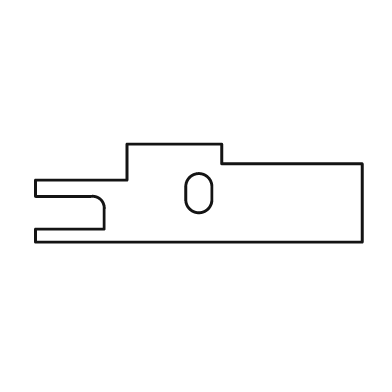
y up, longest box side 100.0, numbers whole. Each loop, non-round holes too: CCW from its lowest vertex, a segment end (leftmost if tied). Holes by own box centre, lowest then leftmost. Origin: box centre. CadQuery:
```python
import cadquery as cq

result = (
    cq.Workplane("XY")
    .moveTo(-50.0, -15.0)
    .lineTo(50.0, -15.0)
    .lineTo(50.0, 9.0)
    .lineTo(7.0, 9.0)
    .lineTo(7.0, 15.0)
    .lineTo(-22.0, 15.0)
    .lineTo(-22.0, 4.0)
    .lineTo(-50.0, 4.0)
    .lineTo(-50.0, -1.0)
    .lineTo(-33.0, -1.0)
    .threePointArc((-30.0, -2.0), (-29.0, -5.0))
    .lineTo(-29.0, -11.0)
    .lineTo(-50.0, -11.0)
    .close()
    .moveTo(-4.0, -2.0)
    .threePointArc((0.0, -6.0), (4.0, -2.0))
    .lineTo(4.0, 2.0)
    .threePointArc((0.0, 6.0), (-4.0, 2.0))
    .close()
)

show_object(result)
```